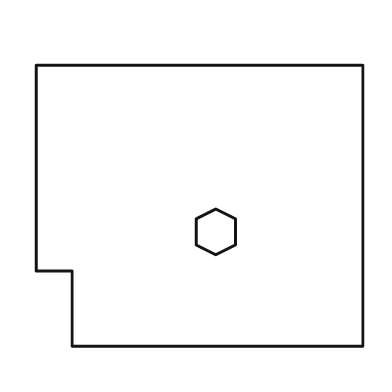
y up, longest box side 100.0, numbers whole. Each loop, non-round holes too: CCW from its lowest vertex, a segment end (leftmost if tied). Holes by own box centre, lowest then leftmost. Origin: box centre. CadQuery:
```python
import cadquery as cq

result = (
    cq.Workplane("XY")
    .moveTo(-39.0, -43.0)
    .lineTo(50.0, -43.0)
    .lineTo(50.0, 43.0)
    .lineTo(-50.0, 43.0)
    .lineTo(-50.0, -20.0)
    .lineTo(-39.0, -20.0)
    .close()
    .moveTo(5.0, -15.0)
    .lineTo(11.0, -12.0)
    .lineTo(11.0, -4.0)
    .lineTo(5.0, -1.0)
    .lineTo(-1.0, -4.0)
    .lineTo(-1.0, -12.0)
    .close()
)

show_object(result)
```